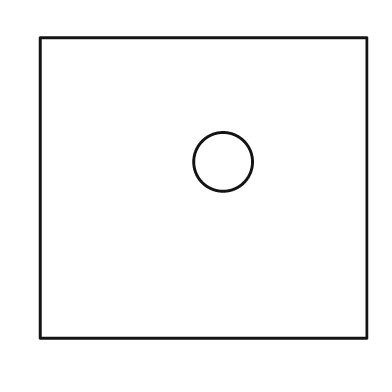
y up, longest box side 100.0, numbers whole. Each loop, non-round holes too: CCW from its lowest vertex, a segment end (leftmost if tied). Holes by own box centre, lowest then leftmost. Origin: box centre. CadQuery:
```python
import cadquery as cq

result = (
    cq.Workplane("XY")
    .moveTo(-50.0, -46.0)
    .lineTo(50.0, -46.0)
    .lineTo(50.0, 46.0)
    .lineTo(-50.0, 46.0)
    .close()
    .moveTo(6.0, 8.0)
    .circle(9.0)
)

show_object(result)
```